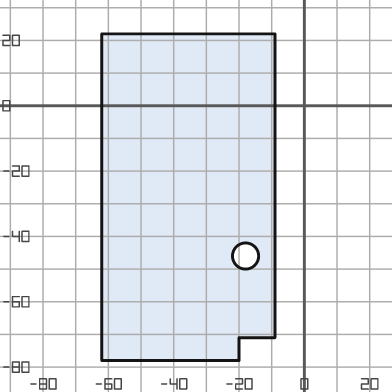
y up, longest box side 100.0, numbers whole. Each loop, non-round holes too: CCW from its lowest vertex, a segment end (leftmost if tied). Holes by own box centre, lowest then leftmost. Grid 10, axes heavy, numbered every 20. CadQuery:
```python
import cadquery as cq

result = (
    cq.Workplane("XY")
    .moveTo(-62.0, -78.0)
    .lineTo(-20.0, -78.0)
    .lineTo(-20.0, -71.0)
    .lineTo(-9.0, -71.0)
    .lineTo(-9.0, 22.0)
    .lineTo(-62.0, 22.0)
    .close()
    .moveTo(-18.0, -46.0)
    .circle(4.0)
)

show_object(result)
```